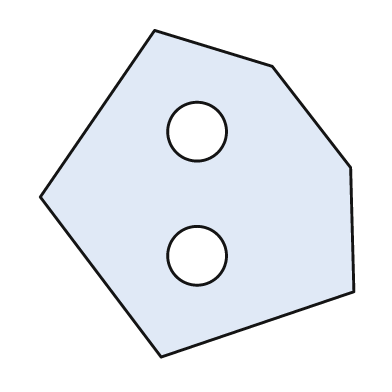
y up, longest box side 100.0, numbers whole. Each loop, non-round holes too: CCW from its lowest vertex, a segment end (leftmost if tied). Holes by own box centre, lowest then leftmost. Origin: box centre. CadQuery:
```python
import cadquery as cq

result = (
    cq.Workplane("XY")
    .moveTo(-11.0, -50.0)
    .lineTo(48.0, -30.0)
    .lineTo(47.0, 8.0)
    .lineTo(23.0, 39.0)
    .lineTo(-13.0, 50.0)
    .lineTo(-48.0, -1.0)
    .close()
    .moveTo(0.0, -19.0)
    .circle(9.0)
    .moveTo(0.0, 19.0)
    .circle(9.0)
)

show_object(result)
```